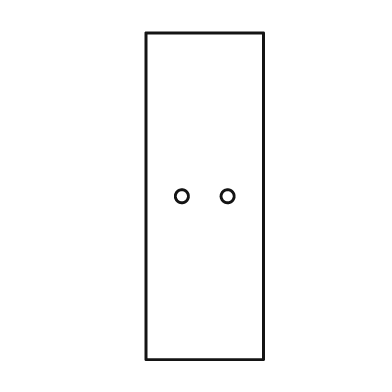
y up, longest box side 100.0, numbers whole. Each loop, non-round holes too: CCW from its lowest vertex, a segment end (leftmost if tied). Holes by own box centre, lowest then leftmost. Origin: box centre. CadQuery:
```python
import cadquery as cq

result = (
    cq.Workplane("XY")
    .moveTo(-18.0, -50.0)
    .lineTo(18.0, -50.0)
    .lineTo(18.0, 50.0)
    .lineTo(-18.0, 50.0)
    .close()
    .moveTo(-7.0, 0.0)
    .circle(2.0)
    .moveTo(7.0, 0.0)
    .circle(2.0)
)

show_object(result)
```